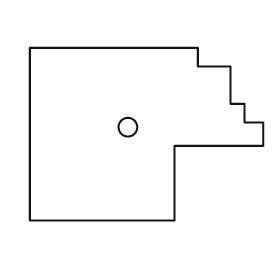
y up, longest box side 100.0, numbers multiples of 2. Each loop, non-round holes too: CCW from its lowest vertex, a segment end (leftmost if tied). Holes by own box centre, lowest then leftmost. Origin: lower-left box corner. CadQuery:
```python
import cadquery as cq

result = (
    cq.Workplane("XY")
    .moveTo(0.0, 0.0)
    .lineTo(62.0, 0.0)
    .lineTo(62.0, 32.0)
    .lineTo(100.0, 32.0)
    .lineTo(100.0, 42.0)
    .lineTo(92.0, 42.0)
    .lineTo(92.0, 50.0)
    .lineTo(86.0, 50.0)
    .lineTo(86.0, 66.0)
    .lineTo(72.0, 66.0)
    .lineTo(72.0, 74.0)
    .lineTo(0.0, 74.0)
    .close()
    .moveTo(42.0, 40.0)
    .circle(4.0)
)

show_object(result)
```